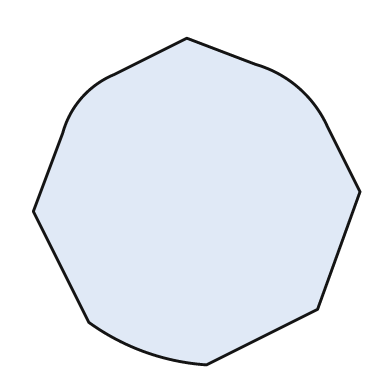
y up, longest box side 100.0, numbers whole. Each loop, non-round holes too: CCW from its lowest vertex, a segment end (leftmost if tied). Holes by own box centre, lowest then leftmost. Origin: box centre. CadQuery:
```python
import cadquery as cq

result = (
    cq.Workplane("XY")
    .moveTo(3.0, -50.0)
    .lineTo(37.0, -33.0)
    .lineTo(50.0, 3.0)
    .lineTo(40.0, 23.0)
    .threePointArc((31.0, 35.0), (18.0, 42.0))
    .lineTo(-3.0, 50.0)
    .lineTo(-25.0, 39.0)
    .threePointArc((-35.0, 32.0), (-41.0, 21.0))
    .lineTo(-50.0, -3.0)
    .lineTo(-33.0, -37.0)
    .threePointArc((-16.0, -46.0), (3.0, -50.0))
    .close()
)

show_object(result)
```